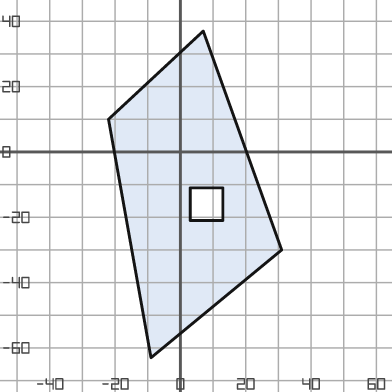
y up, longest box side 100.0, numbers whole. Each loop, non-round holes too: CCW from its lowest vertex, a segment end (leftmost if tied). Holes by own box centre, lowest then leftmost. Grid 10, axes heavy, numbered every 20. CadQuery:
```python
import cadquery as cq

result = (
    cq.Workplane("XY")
    .moveTo(-9.0, -63.0)
    .lineTo(31.0, -30.0)
    .lineTo(7.0, 37.0)
    .lineTo(-22.0, 10.0)
    .close()
    .moveTo(3.0, -21.0)
    .lineTo(13.0, -21.0)
    .lineTo(13.0, -11.0)
    .lineTo(3.0, -11.0)
    .close()
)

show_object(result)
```